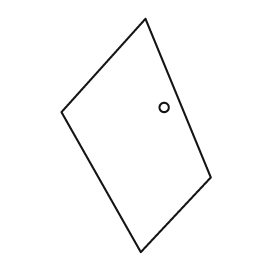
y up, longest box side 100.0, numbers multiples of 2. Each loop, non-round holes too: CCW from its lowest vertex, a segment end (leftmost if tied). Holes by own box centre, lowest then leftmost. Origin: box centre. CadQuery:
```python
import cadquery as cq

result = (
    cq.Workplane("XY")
    .moveTo(2.0, -50.0)
    .lineTo(32.0, -18.0)
    .lineTo(4.0, 50.0)
    .lineTo(-32.0, 10.0)
    .close()
    .moveTo(12.0, 12.0)
    .circle(2.0)
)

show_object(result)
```